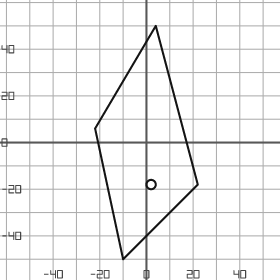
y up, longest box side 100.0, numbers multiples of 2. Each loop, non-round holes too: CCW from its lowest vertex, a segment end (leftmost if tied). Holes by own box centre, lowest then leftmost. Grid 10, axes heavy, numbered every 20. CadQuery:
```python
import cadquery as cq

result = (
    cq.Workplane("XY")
    .moveTo(-10.0, -50.0)
    .lineTo(22.0, -18.0)
    .lineTo(4.0, 50.0)
    .lineTo(-22.0, 6.0)
    .close()
    .moveTo(2.0, -18.0)
    .circle(2.0)
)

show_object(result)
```